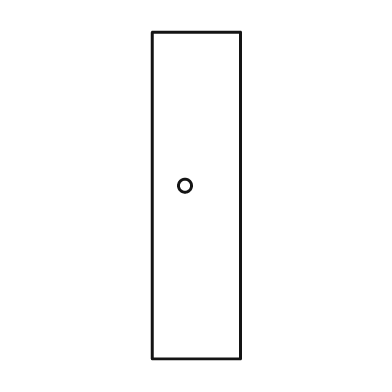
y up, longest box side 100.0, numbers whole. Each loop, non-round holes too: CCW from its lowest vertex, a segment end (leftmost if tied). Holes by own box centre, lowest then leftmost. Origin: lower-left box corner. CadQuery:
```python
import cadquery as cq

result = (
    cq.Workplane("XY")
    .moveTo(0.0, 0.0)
    .lineTo(27.0, 0.0)
    .lineTo(27.0, 100.0)
    .lineTo(0.0, 100.0)
    .close()
    .moveTo(10.0, 53.0)
    .circle(2.0)
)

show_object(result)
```